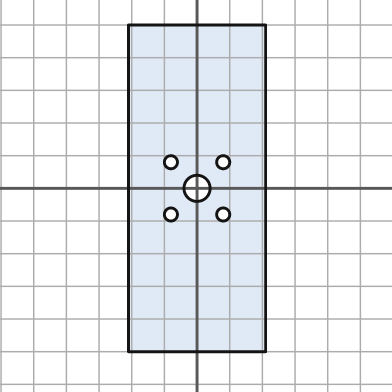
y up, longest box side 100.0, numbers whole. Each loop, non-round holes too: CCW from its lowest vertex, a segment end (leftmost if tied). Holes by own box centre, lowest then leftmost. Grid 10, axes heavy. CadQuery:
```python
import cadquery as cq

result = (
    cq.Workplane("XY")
    .moveTo(-21.0, -50.0)
    .lineTo(21.0, -50.0)
    .lineTo(21.0, 50.0)
    .lineTo(-21.0, 50.0)
    .close()
    .moveTo(-8.0, -8.0)
    .circle(2.0)
    .moveTo(8.0, -8.0)
    .circle(2.0)
    .moveTo(0.0, 0.0)
    .circle(4.0)
    .moveTo(-8.0, 8.0)
    .circle(2.0)
    .moveTo(8.0, 8.0)
    .circle(2.0)
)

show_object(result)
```